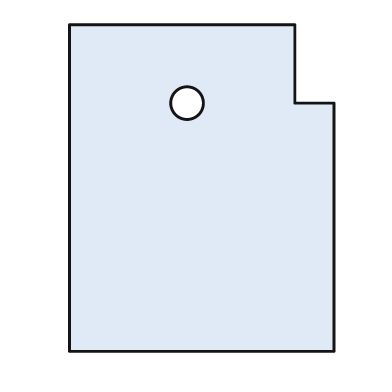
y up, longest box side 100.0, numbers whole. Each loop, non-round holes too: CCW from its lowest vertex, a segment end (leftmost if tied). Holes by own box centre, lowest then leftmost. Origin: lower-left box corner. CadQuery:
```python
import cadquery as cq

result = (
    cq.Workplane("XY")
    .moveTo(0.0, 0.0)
    .lineTo(81.0, 0.0)
    .lineTo(81.0, 76.0)
    .lineTo(69.0, 76.0)
    .lineTo(69.0, 100.0)
    .lineTo(0.0, 100.0)
    .close()
    .moveTo(36.0, 76.0)
    .circle(5.0)
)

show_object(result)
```